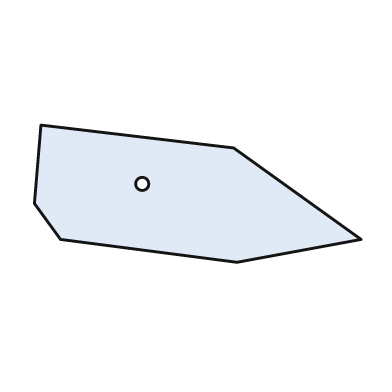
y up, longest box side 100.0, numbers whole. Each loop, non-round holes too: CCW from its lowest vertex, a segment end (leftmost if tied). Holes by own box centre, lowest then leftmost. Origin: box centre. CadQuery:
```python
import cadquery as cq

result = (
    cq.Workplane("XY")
    .moveTo(12.0, -21.0)
    .lineTo(50.0, -14.0)
    .lineTo(11.0, 14.0)
    .lineTo(-48.0, 21.0)
    .lineTo(-50.0, -3.0)
    .lineTo(-42.0, -14.0)
    .close()
    .moveTo(-17.0, 3.0)
    .circle(2.0)
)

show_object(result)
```